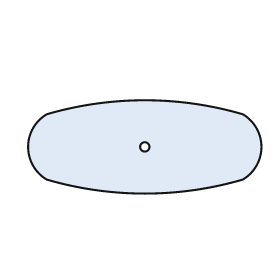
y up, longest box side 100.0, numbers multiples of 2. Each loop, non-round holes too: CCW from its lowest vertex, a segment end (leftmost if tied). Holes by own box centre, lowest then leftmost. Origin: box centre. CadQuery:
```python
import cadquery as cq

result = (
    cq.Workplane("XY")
    .moveTo(-42.0, -14.0)
    .threePointArc((0.0, -20.0), (42.0, -14.0))
    .threePointArc((50.0, 0.0), (42.0, 14.0))
    .threePointArc((0.0, 20.0), (-42.0, 14.0))
    .threePointArc((-50.0, 0.0), (-42.0, -14.0))
    .close()
    .moveTo(0.0, 0.0)
    .circle(2.0)
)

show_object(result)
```